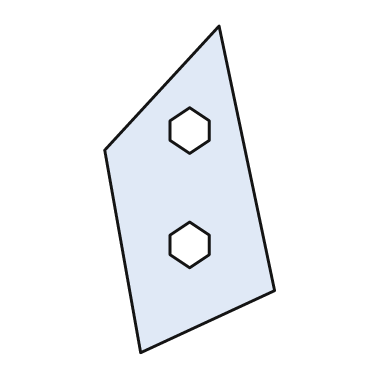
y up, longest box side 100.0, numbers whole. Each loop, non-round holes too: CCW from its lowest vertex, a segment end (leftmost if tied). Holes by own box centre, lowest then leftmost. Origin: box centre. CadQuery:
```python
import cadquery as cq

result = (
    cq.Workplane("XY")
    .moveTo(-15.0, -50.0)
    .lineTo(26.0, -31.0)
    .lineTo(9.0, 50.0)
    .lineTo(-26.0, 12.0)
    .close()
    .moveTo(0.0, -24.0)
    .lineTo(6.0, -20.0)
    .lineTo(6.0, -14.0)
    .lineTo(0.0, -10.0)
    .lineTo(-6.0, -14.0)
    .lineTo(-6.0, -20.0)
    .close()
    .moveTo(0.0, 11.0)
    .lineTo(6.0, 15.0)
    .lineTo(6.0, 21.0)
    .lineTo(0.0, 25.0)
    .lineTo(-6.0, 21.0)
    .lineTo(-6.0, 15.0)
    .close()
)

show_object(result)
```